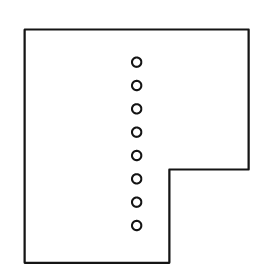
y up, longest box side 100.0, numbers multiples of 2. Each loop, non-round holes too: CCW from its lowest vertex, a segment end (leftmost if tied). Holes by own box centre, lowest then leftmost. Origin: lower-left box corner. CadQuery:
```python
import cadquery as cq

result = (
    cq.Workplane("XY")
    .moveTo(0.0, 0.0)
    .lineTo(62.0, 0.0)
    .lineTo(62.0, 40.0)
    .lineTo(96.0, 40.0)
    .lineTo(96.0, 100.0)
    .lineTo(0.0, 100.0)
    .close()
    .moveTo(48.0, 16.0)
    .circle(2.0)
    .moveTo(48.0, 26.0)
    .circle(2.0)
    .moveTo(48.0, 36.0)
    .circle(2.0)
    .moveTo(48.0, 46.0)
    .circle(2.0)
    .moveTo(48.0, 56.0)
    .circle(2.0)
    .moveTo(48.0, 66.0)
    .circle(2.0)
    .moveTo(48.0, 76.0)
    .circle(2.0)
    .moveTo(48.0, 86.0)
    .circle(2.0)
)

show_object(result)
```